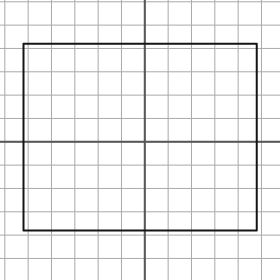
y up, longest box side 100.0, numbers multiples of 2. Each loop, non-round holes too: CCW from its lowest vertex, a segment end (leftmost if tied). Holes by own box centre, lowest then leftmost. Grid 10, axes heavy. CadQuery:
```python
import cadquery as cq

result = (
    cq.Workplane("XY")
    .moveTo(-52.0, -38.0)
    .lineTo(48.0, -38.0)
    .lineTo(48.0, 42.0)
    .lineTo(-52.0, 42.0)
    .close()
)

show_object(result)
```